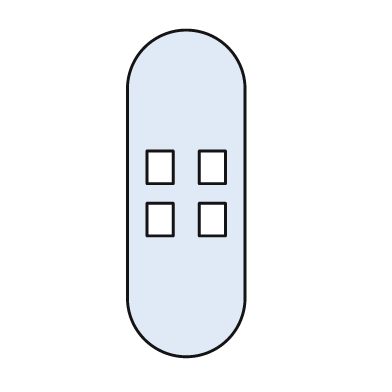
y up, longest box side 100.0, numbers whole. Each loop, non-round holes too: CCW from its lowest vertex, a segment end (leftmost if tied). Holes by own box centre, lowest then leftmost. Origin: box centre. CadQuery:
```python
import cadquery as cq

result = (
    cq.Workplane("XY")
    .moveTo(-18.0, -32.0)
    .threePointArc((0.0, -50.0), (18.0, -32.0))
    .lineTo(18.0, 32.0)
    .threePointArc((0.0, 50.0), (-18.0, 32.0))
    .close()
    .moveTo(-12.0, -13.0)
    .lineTo(-4.0, -13.0)
    .lineTo(-4.0, -3.0)
    .lineTo(-12.0, -3.0)
    .close()
    .moveTo(4.0, -13.0)
    .lineTo(12.0, -13.0)
    .lineTo(12.0, -3.0)
    .lineTo(4.0, -3.0)
    .close()
    .moveTo(-12.0, 3.0)
    .lineTo(-4.0, 3.0)
    .lineTo(-4.0, 13.0)
    .lineTo(-12.0, 13.0)
    .close()
    .moveTo(4.0, 3.0)
    .lineTo(12.0, 3.0)
    .lineTo(12.0, 13.0)
    .lineTo(4.0, 13.0)
    .close()
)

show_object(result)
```